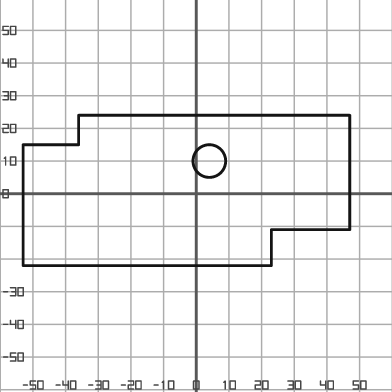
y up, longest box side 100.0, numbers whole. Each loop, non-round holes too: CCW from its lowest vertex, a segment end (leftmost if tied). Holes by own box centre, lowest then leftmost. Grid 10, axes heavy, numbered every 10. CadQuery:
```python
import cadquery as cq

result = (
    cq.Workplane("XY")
    .moveTo(-53.0, -22.0)
    .lineTo(23.0, -22.0)
    .lineTo(23.0, -11.0)
    .lineTo(47.0, -11.0)
    .lineTo(47.0, 24.0)
    .lineTo(-36.0, 24.0)
    .lineTo(-36.0, 15.0)
    .lineTo(-53.0, 15.0)
    .close()
    .moveTo(4.0, 10.0)
    .circle(5.0)
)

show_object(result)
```